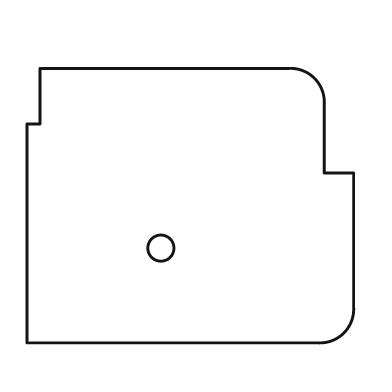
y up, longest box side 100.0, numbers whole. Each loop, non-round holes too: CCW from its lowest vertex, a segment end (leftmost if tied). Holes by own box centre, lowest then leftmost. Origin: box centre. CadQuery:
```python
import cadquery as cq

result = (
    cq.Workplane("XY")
    .moveTo(-50.0, -42.0)
    .lineTo(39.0, -42.0)
    .threePointArc((47.0, -39.0), (50.0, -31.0))
    .lineTo(50.0, 10.0)
    .lineTo(41.0, 10.0)
    .lineTo(41.0, 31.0)
    .threePointArc((38.0, 39.0), (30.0, 42.0))
    .lineTo(-46.0, 42.0)
    .lineTo(-46.0, 25.0)
    .lineTo(-50.0, 25.0)
    .close()
    .moveTo(-9.0, -13.0)
    .circle(4.0)
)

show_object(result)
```